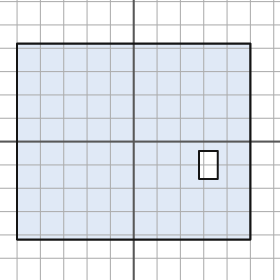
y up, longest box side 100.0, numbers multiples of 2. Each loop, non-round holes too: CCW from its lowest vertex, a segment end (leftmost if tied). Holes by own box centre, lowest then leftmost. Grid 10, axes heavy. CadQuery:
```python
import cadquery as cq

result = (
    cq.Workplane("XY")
    .moveTo(-50.0, -42.0)
    .lineTo(50.0, -42.0)
    .lineTo(50.0, 42.0)
    .lineTo(-50.0, 42.0)
    .close()
    .moveTo(28.0, -16.0)
    .lineTo(36.0, -16.0)
    .lineTo(36.0, -4.0)
    .lineTo(28.0, -4.0)
    .close()
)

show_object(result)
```